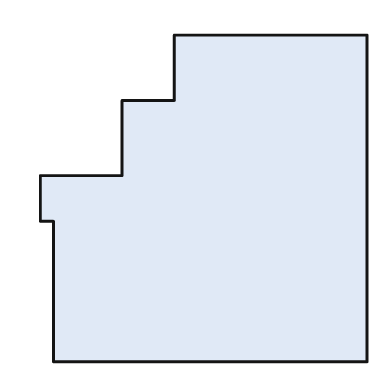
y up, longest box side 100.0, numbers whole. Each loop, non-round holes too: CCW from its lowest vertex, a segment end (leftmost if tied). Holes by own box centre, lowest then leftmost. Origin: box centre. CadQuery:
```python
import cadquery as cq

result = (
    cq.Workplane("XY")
    .moveTo(-46.0, -50.0)
    .lineTo(50.0, -50.0)
    .lineTo(50.0, 50.0)
    .lineTo(-9.0, 50.0)
    .lineTo(-9.0, 30.0)
    .lineTo(-25.0, 30.0)
    .lineTo(-25.0, 7.0)
    .lineTo(-50.0, 7.0)
    .lineTo(-50.0, -7.0)
    .lineTo(-46.0, -7.0)
    .close()
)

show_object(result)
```